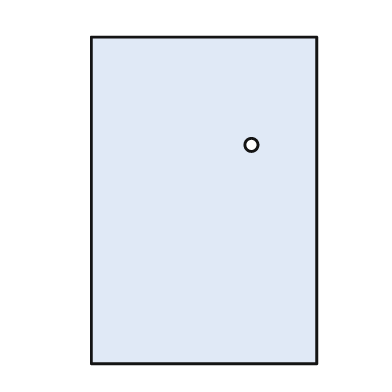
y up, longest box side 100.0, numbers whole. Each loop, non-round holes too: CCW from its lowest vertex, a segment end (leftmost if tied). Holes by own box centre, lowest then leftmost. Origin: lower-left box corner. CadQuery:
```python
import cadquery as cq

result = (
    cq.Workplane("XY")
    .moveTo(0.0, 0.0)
    .lineTo(69.0, 0.0)
    .lineTo(69.0, 100.0)
    .lineTo(0.0, 100.0)
    .close()
    .moveTo(49.0, 67.0)
    .circle(2.0)
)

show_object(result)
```